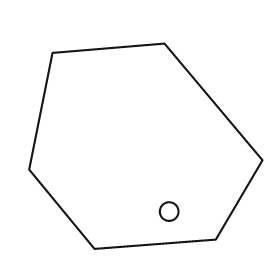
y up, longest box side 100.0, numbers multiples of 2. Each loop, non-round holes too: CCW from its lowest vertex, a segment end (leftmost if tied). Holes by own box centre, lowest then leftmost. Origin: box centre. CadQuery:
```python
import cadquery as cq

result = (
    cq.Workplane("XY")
    .moveTo(-22.0, -44.0)
    .lineTo(30.0, -40.0)
    .lineTo(50.0, -6.0)
    .lineTo(8.0, 44.0)
    .lineTo(-40.0, 40.0)
    .lineTo(-50.0, -10.0)
    .close()
    .moveTo(10.0, -28.0)
    .circle(4.0)
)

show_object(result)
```